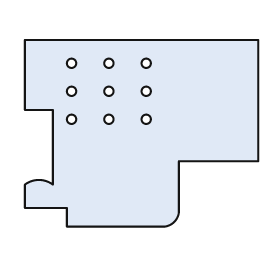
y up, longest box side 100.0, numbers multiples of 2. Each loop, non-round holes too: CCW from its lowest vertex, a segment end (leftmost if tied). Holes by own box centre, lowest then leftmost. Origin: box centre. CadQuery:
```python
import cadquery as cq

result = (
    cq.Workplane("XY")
    .moveTo(-32.0, -40.0)
    .lineTo(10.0, -40.0)
    .threePointArc((14.0, -38.0), (16.0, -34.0))
    .lineTo(16.0, -12.0)
    .lineTo(50.0, -12.0)
    .lineTo(50.0, 40.0)
    .lineTo(-50.0, 40.0)
    .lineTo(-50.0, 10.0)
    .lineTo(-38.0, 10.0)
    .lineTo(-38.0, -22.0)
    .threePointArc((-44.0, -20.0), (-50.0, -22.0))
    .lineTo(-50.0, -32.0)
    .lineTo(-32.0, -32.0)
    .close()
    .moveTo(-30.0, 6.0)
    .circle(2.0)
    .moveTo(-14.0, 6.0)
    .circle(2.0)
    .moveTo(2.0, 6.0)
    .circle(2.0)
    .moveTo(-30.0, 18.0)
    .circle(2.0)
    .moveTo(-14.0, 18.0)
    .circle(2.0)
    .moveTo(2.0, 18.0)
    .circle(2.0)
    .moveTo(-30.0, 30.0)
    .circle(2.0)
    .moveTo(-14.0, 30.0)
    .circle(2.0)
    .moveTo(2.0, 30.0)
    .circle(2.0)
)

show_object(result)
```